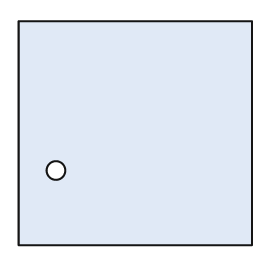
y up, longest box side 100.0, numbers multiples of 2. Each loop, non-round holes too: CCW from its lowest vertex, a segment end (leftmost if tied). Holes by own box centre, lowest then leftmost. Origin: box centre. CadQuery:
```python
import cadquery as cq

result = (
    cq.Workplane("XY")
    .moveTo(-50.0, -48.0)
    .lineTo(50.0, -48.0)
    .lineTo(50.0, 48.0)
    .lineTo(-50.0, 48.0)
    .close()
    .moveTo(-34.0, -16.0)
    .circle(4.0)
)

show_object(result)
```